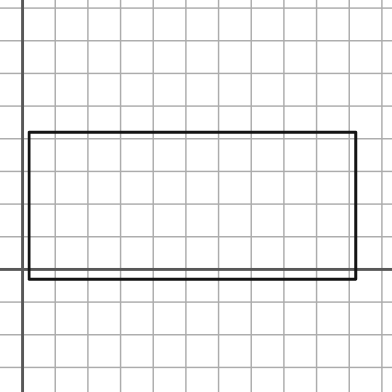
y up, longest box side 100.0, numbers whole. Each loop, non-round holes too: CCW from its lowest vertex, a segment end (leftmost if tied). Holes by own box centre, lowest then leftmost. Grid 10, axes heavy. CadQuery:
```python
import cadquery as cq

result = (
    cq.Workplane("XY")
    .moveTo(2.0, -3.0)
    .lineTo(102.0, -3.0)
    .lineTo(102.0, 42.0)
    .lineTo(2.0, 42.0)
    .close()
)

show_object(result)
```